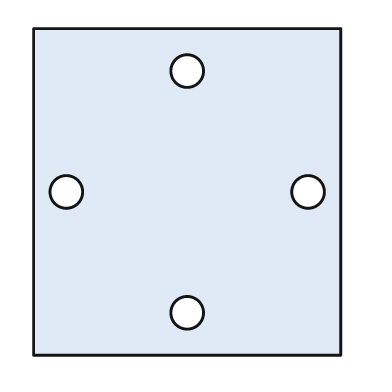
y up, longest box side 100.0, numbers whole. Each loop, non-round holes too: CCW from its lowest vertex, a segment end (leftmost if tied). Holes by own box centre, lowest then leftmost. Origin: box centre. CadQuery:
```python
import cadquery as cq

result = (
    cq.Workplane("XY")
    .moveTo(-47.0, -50.0)
    .lineTo(47.0, -50.0)
    .lineTo(47.0, 50.0)
    .lineTo(-47.0, 50.0)
    .close()
    .moveTo(0.0, -37.0)
    .circle(5.0)
    .moveTo(-37.0, 0.0)
    .circle(5.0)
    .moveTo(37.0, 0.0)
    .circle(5.0)
    .moveTo(0.0, 37.0)
    .circle(5.0)
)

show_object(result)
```